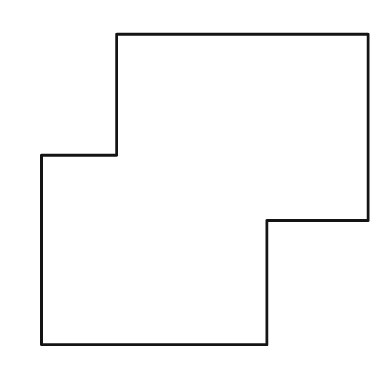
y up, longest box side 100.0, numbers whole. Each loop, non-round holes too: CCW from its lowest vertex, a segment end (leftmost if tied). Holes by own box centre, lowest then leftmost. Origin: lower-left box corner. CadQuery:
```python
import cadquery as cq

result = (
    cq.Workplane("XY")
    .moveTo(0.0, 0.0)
    .lineTo(69.0, 0.0)
    .lineTo(69.0, 38.0)
    .lineTo(100.0, 38.0)
    .lineTo(100.0, 95.0)
    .lineTo(23.0, 95.0)
    .lineTo(23.0, 58.0)
    .lineTo(0.0, 58.0)
    .close()
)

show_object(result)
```